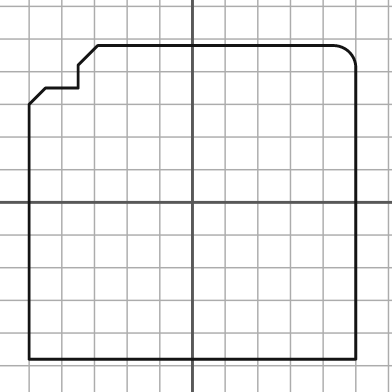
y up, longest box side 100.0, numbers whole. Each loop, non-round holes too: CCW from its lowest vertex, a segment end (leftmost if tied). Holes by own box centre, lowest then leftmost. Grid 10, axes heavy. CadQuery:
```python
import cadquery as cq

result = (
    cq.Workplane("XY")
    .moveTo(-50.0, -48.0)
    .lineTo(50.0, -48.0)
    .lineTo(50.0, 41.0)
    .threePointArc((48.0, 46.0), (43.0, 48.0))
    .lineTo(-29.0, 48.0)
    .lineTo(-35.0, 42.0)
    .lineTo(-35.0, 35.0)
    .lineTo(-45.0, 35.0)
    .lineTo(-50.0, 30.0)
    .close()
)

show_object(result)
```